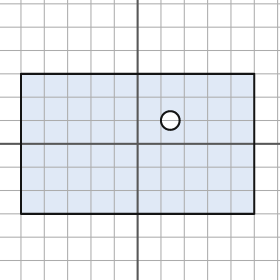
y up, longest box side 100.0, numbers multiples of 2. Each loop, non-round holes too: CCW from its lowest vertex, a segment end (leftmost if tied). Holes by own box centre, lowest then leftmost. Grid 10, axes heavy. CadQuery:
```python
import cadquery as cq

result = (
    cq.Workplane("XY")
    .moveTo(-50.0, -30.0)
    .lineTo(50.0, -30.0)
    .lineTo(50.0, 30.0)
    .lineTo(-50.0, 30.0)
    .close()
    .moveTo(14.0, 10.0)
    .circle(4.0)
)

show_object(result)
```